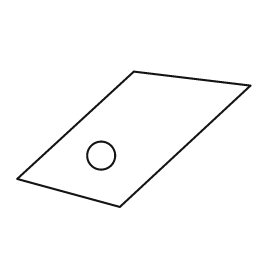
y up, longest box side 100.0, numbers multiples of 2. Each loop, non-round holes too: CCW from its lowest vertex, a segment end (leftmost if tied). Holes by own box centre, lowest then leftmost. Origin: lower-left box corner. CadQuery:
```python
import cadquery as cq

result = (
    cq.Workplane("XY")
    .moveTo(44.0, 0.0)
    .lineTo(100.0, 52.0)
    .lineTo(50.0, 58.0)
    .lineTo(0.0, 12.0)
    .close()
    .moveTo(36.0, 22.0)
    .circle(6.0)
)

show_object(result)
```